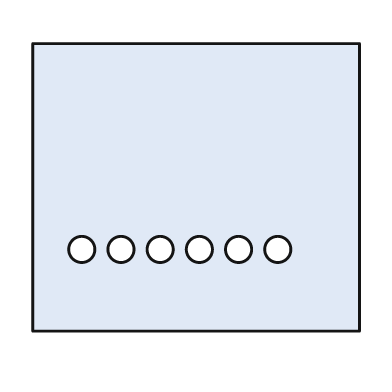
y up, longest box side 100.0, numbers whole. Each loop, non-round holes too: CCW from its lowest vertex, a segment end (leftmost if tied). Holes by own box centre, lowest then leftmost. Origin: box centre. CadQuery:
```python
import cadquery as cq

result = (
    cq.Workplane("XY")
    .moveTo(-50.0, -44.0)
    .lineTo(50.0, -44.0)
    .lineTo(50.0, 44.0)
    .lineTo(-50.0, 44.0)
    .close()
    .moveTo(-35.0, -19.0)
    .circle(4.0)
    .moveTo(-23.0, -19.0)
    .circle(4.0)
    .moveTo(-11.0, -19.0)
    .circle(4.0)
    .moveTo(1.0, -19.0)
    .circle(4.0)
    .moveTo(13.0, -19.0)
    .circle(4.0)
    .moveTo(25.0, -19.0)
    .circle(4.0)
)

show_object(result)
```